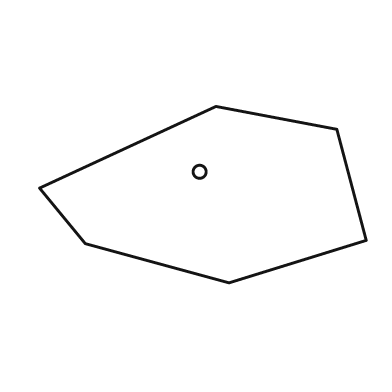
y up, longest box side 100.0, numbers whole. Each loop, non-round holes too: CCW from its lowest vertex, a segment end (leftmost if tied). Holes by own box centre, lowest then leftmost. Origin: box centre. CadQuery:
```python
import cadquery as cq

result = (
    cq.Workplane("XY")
    .moveTo(8.0, -27.0)
    .lineTo(50.0, -14.0)
    .lineTo(41.0, 20.0)
    .lineTo(4.0, 27.0)
    .lineTo(-50.0, 2.0)
    .lineTo(-36.0, -15.0)
    .close()
    .moveTo(-1.0, 7.0)
    .circle(2.0)
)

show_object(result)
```